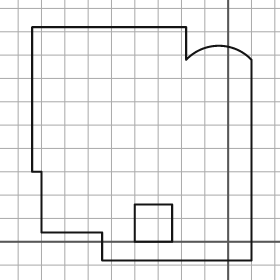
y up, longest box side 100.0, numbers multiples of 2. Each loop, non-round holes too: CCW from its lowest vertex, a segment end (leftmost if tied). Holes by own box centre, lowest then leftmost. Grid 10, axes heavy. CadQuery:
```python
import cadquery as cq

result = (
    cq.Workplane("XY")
    .moveTo(-54.0, -8.0)
    .lineTo(10.0, -8.0)
    .lineTo(10.0, 78.0)
    .threePointArc((-4.0, 84.0), (-18.0, 78.0))
    .lineTo(-18.0, 92.0)
    .lineTo(-84.0, 92.0)
    .lineTo(-84.0, 30.0)
    .lineTo(-80.0, 30.0)
    .lineTo(-80.0, 4.0)
    .lineTo(-54.0, 4.0)
    .close()
    .moveTo(-40.0, 0.0)
    .lineTo(-24.0, 0.0)
    .lineTo(-24.0, 16.0)
    .lineTo(-40.0, 16.0)
    .close()
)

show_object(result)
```